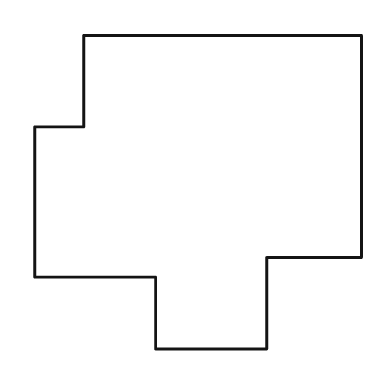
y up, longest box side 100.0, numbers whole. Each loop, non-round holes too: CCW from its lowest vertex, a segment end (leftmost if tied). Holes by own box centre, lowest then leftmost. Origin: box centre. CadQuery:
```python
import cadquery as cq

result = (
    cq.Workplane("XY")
    .moveTo(-13.0, -48.0)
    .lineTo(21.0, -48.0)
    .lineTo(21.0, -20.0)
    .lineTo(50.0, -20.0)
    .lineTo(50.0, 48.0)
    .lineTo(-35.0, 48.0)
    .lineTo(-35.0, 20.0)
    .lineTo(-50.0, 20.0)
    .lineTo(-50.0, -26.0)
    .lineTo(-13.0, -26.0)
    .close()
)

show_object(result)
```